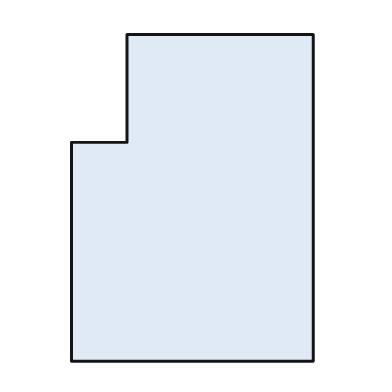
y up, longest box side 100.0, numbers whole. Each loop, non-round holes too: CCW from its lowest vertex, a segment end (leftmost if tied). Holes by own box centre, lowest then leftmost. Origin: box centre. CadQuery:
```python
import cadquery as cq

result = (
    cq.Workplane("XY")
    .moveTo(-37.0, -50.0)
    .lineTo(37.0, -50.0)
    .lineTo(37.0, 50.0)
    .lineTo(-20.0, 50.0)
    .lineTo(-20.0, 17.0)
    .lineTo(-37.0, 17.0)
    .close()
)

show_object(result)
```